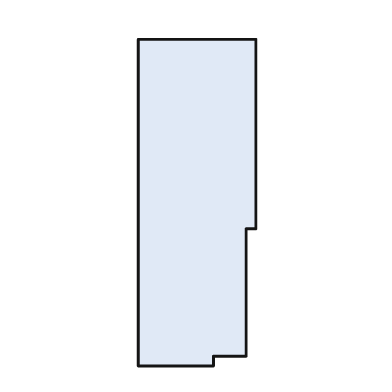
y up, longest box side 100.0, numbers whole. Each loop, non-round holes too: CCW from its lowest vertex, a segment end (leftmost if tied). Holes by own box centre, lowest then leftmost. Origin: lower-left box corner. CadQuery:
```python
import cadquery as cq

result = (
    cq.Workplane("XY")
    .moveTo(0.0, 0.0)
    .lineTo(23.0, 0.0)
    .lineTo(23.0, 3.0)
    .lineTo(33.0, 3.0)
    .lineTo(33.0, 42.0)
    .lineTo(36.0, 42.0)
    .lineTo(36.0, 100.0)
    .lineTo(0.0, 100.0)
    .close()
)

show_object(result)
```